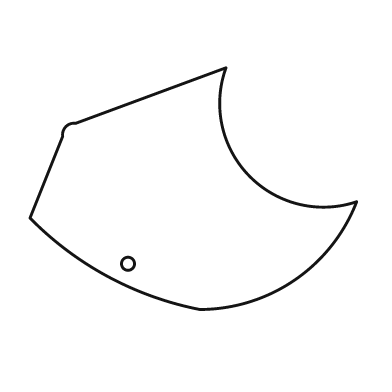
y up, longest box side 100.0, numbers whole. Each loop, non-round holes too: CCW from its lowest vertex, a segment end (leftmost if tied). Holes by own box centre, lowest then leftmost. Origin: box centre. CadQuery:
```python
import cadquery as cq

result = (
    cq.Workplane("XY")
    .moveTo(2.0, -37.0)
    .threePointArc((31.0, -28.0), (50.0, -4.0))
    .threePointArc((17.0, 4.0), (10.0, 37.0))
    .lineTo(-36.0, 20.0)
    .threePointArc((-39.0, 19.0), (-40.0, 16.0))
    .lineTo(-50.0, -9.0)
    .threePointArc((-26.0, -27.0), (2.0, -37.0))
    .close()
    .moveTo(-20.0, -23.0)
    .circle(2.0)
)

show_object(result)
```